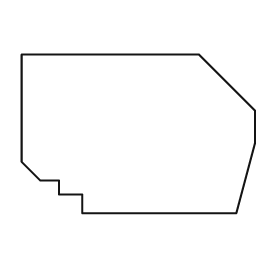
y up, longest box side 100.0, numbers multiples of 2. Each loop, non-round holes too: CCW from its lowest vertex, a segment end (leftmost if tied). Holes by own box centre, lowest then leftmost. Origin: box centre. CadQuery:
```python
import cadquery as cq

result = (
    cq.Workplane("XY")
    .moveTo(-24.0, -34.0)
    .lineTo(42.0, -34.0)
    .lineTo(50.0, -4.0)
    .lineTo(50.0, 10.0)
    .lineTo(26.0, 34.0)
    .lineTo(-50.0, 34.0)
    .lineTo(-50.0, -12.0)
    .lineTo(-42.0, -20.0)
    .lineTo(-34.0, -20.0)
    .lineTo(-34.0, -26.0)
    .lineTo(-24.0, -26.0)
    .close()
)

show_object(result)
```